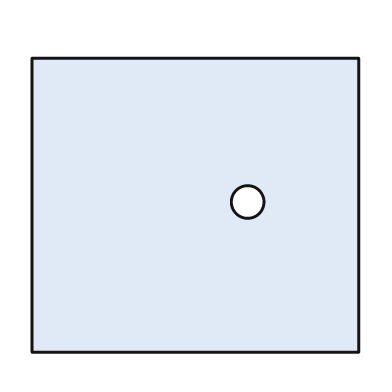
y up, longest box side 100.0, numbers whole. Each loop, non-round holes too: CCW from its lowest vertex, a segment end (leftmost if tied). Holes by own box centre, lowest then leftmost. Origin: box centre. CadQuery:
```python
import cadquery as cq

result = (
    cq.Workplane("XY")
    .moveTo(-50.0, -45.0)
    .lineTo(50.0, -45.0)
    .lineTo(50.0, 45.0)
    .lineTo(-50.0, 45.0)
    .close()
    .moveTo(16.0, 1.0)
    .circle(5.0)
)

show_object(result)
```